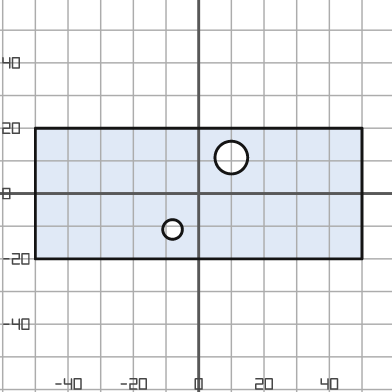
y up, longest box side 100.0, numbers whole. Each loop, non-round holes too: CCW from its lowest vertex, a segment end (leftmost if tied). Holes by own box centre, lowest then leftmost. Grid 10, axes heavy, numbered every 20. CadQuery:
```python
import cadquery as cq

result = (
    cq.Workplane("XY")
    .moveTo(-50.0, -20.0)
    .lineTo(50.0, -20.0)
    .lineTo(50.0, 20.0)
    .lineTo(-50.0, 20.0)
    .close()
    .moveTo(-8.0, -11.0)
    .circle(3.0)
    .moveTo(10.0, 11.0)
    .circle(5.0)
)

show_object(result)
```